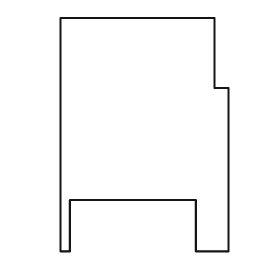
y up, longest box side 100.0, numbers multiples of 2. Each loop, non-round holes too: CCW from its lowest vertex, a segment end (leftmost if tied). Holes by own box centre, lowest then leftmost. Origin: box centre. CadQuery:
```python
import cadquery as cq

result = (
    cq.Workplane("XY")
    .moveTo(-36.0, -50.0)
    .lineTo(-32.0, -50.0)
    .lineTo(-32.0, -28.0)
    .lineTo(22.0, -28.0)
    .lineTo(22.0, -50.0)
    .lineTo(36.0, -50.0)
    .lineTo(36.0, 20.0)
    .lineTo(30.0, 20.0)
    .lineTo(30.0, 50.0)
    .lineTo(-36.0, 50.0)
    .close()
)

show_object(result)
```